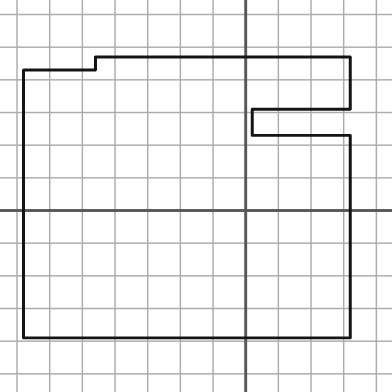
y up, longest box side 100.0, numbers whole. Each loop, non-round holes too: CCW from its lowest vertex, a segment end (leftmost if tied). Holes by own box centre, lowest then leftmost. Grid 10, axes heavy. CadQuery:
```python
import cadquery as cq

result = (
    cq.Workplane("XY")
    .moveTo(-68.0, -39.0)
    .lineTo(32.0, -39.0)
    .lineTo(32.0, 23.0)
    .lineTo(2.0, 23.0)
    .lineTo(2.0, 31.0)
    .lineTo(32.0, 31.0)
    .lineTo(32.0, 47.0)
    .lineTo(-46.0, 47.0)
    .lineTo(-46.0, 43.0)
    .lineTo(-68.0, 43.0)
    .close()
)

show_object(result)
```